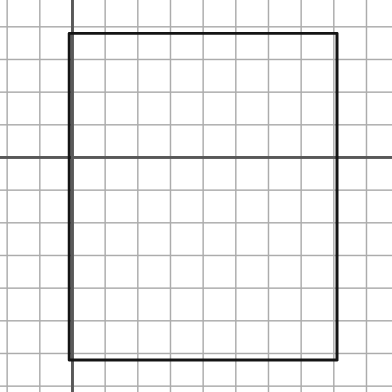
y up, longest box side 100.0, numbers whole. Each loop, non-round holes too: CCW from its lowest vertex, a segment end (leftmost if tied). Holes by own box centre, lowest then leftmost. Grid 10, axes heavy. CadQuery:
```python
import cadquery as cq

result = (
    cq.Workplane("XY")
    .moveTo(-1.0, -62.0)
    .lineTo(81.0, -62.0)
    .lineTo(81.0, 38.0)
    .lineTo(-1.0, 38.0)
    .close()
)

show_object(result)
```